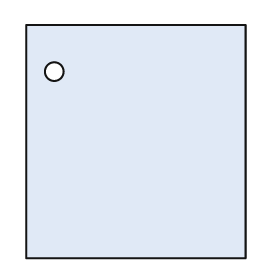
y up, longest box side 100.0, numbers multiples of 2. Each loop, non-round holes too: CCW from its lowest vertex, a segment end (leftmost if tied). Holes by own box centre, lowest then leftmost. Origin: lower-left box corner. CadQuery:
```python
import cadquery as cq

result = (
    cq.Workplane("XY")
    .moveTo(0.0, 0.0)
    .lineTo(94.0, 0.0)
    .lineTo(94.0, 100.0)
    .lineTo(0.0, 100.0)
    .close()
    .moveTo(12.0, 80.0)
    .circle(4.0)
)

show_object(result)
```